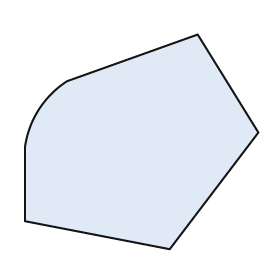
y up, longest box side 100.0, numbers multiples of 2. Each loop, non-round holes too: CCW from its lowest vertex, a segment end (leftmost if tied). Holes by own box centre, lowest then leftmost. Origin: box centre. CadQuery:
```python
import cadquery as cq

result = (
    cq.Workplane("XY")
    .moveTo(12.0, -46.0)
    .lineTo(50.0, 4.0)
    .lineTo(24.0, 46.0)
    .lineTo(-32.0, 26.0)
    .threePointArc((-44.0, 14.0), (-50.0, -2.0))
    .lineTo(-50.0, -34.0)
    .close()
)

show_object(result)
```